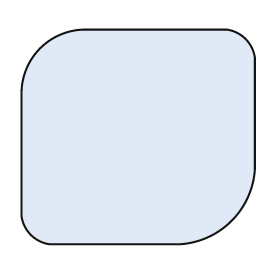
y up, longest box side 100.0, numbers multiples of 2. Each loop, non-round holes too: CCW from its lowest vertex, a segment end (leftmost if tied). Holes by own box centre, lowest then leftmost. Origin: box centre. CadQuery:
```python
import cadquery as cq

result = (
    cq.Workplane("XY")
    .moveTo(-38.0, -46.0)
    .lineTo(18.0, -46.0)
    .threePointArc((40.0, -36.0), (50.0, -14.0))
    .lineTo(50.0, 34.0)
    .threePointArc((46.0, 42.0), (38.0, 46.0))
    .lineTo(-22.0, 46.0)
    .threePointArc((-42.0, 38.0), (-50.0, 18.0))
    .lineTo(-50.0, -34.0)
    .threePointArc((-46.0, -42.0), (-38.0, -46.0))
    .close()
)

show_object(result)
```